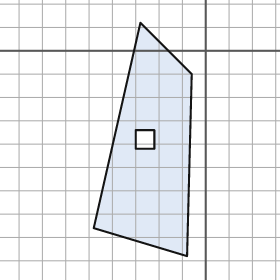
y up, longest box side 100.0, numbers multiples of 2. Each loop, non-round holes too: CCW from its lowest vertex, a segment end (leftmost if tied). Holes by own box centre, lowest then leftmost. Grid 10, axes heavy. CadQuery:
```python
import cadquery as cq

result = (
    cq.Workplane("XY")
    .moveTo(-8.0, -88.0)
    .lineTo(-6.0, -10.0)
    .lineTo(-28.0, 12.0)
    .lineTo(-48.0, -76.0)
    .close()
    .moveTo(-30.0, -42.0)
    .lineTo(-22.0, -42.0)
    .lineTo(-22.0, -34.0)
    .lineTo(-30.0, -34.0)
    .close()
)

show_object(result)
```